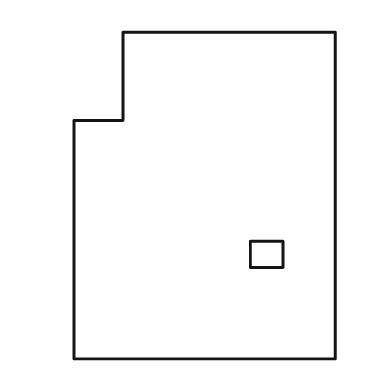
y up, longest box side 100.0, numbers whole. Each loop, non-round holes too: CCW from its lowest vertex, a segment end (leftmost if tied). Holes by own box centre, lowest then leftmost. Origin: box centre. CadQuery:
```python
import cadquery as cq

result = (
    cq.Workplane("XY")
    .moveTo(-40.0, -50.0)
    .lineTo(40.0, -50.0)
    .lineTo(40.0, 50.0)
    .lineTo(-25.0, 50.0)
    .lineTo(-25.0, 23.0)
    .lineTo(-40.0, 23.0)
    .close()
    .moveTo(14.0, -22.0)
    .lineTo(24.0, -22.0)
    .lineTo(24.0, -14.0)
    .lineTo(14.0, -14.0)
    .close()
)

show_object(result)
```